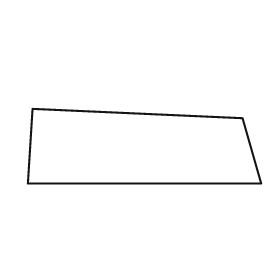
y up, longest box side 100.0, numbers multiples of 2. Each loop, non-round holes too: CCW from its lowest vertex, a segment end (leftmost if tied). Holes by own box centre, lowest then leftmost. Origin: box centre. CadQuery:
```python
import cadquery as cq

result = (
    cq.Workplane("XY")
    .moveTo(-50.0, -16.0)
    .lineTo(50.0, -16.0)
    .lineTo(42.0, 12.0)
    .lineTo(-48.0, 16.0)
    .close()
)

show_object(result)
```